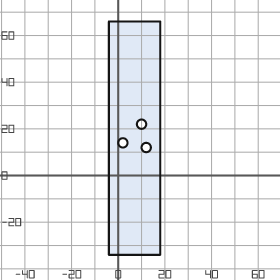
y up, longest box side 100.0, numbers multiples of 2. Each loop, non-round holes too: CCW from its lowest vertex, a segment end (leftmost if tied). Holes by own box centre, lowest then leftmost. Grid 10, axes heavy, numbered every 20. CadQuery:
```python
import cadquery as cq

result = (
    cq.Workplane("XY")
    .moveTo(-4.0, -34.0)
    .lineTo(18.0, -34.0)
    .lineTo(18.0, 66.0)
    .lineTo(-4.0, 66.0)
    .close()
    .moveTo(12.0, 12.0)
    .circle(2.0)
    .moveTo(2.0, 14.0)
    .circle(2.0)
    .moveTo(10.0, 22.0)
    .circle(2.0)
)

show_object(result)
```